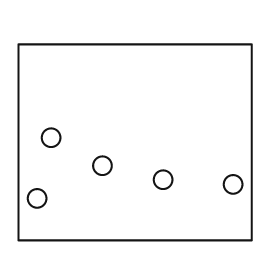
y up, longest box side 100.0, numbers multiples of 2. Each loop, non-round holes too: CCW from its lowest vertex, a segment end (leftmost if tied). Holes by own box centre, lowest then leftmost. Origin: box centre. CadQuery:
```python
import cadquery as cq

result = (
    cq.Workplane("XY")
    .moveTo(-50.0, -42.0)
    .lineTo(50.0, -42.0)
    .lineTo(50.0, 42.0)
    .lineTo(-50.0, 42.0)
    .close()
    .moveTo(-42.0, -24.0)
    .circle(4.0)
    .moveTo(42.0, -18.0)
    .circle(4.0)
    .moveTo(12.0, -16.0)
    .circle(4.0)
    .moveTo(-14.0, -10.0)
    .circle(4.0)
    .moveTo(-36.0, 2.0)
    .circle(4.0)
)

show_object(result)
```